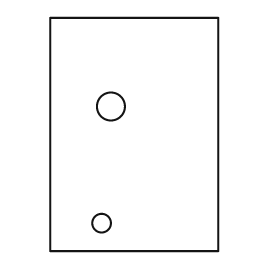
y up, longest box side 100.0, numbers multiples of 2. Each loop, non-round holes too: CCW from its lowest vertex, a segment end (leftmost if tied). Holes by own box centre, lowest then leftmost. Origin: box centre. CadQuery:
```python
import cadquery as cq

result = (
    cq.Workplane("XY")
    .moveTo(-36.0, -50.0)
    .lineTo(36.0, -50.0)
    .lineTo(36.0, 50.0)
    .lineTo(-36.0, 50.0)
    .close()
    .moveTo(-14.0, -38.0)
    .circle(4.0)
    .moveTo(-10.0, 12.0)
    .circle(6.0)
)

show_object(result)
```